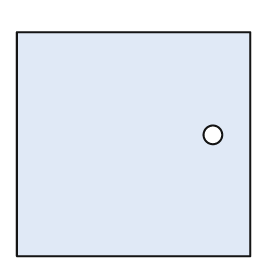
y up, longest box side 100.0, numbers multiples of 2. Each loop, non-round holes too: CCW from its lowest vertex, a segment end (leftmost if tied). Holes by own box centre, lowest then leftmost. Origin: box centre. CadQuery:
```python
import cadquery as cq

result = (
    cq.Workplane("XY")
    .moveTo(-50.0, -48.0)
    .lineTo(50.0, -48.0)
    .lineTo(50.0, 48.0)
    .lineTo(-50.0, 48.0)
    .close()
    .moveTo(34.0, 4.0)
    .circle(4.0)
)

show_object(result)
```